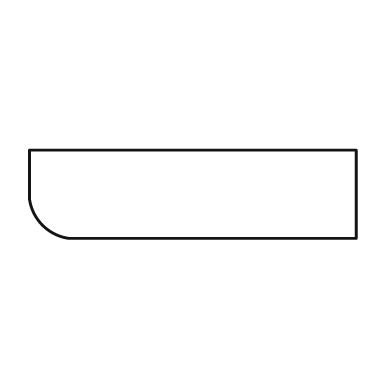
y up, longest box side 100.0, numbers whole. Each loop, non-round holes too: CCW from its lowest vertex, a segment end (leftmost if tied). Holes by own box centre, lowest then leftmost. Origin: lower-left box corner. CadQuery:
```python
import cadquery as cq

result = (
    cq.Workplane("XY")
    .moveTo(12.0, 0.0)
    .lineTo(100.0, 0.0)
    .lineTo(100.0, 27.0)
    .lineTo(0.0, 27.0)
    .lineTo(0.0, 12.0)
    .threePointArc((4.0, 4.0), (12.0, 0.0))
    .close()
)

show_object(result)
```